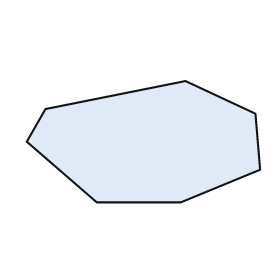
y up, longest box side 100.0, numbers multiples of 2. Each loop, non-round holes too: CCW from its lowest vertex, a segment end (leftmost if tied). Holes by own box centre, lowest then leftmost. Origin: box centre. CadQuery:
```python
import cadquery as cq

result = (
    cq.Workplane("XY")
    .moveTo(-20.0, -26.0)
    .lineTo(16.0, -26.0)
    .lineTo(50.0, -12.0)
    .lineTo(48.0, 12.0)
    .lineTo(18.0, 26.0)
    .lineTo(-42.0, 14.0)
    .lineTo(-50.0, 0.0)
    .close()
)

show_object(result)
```